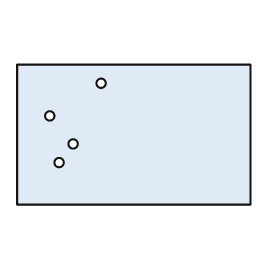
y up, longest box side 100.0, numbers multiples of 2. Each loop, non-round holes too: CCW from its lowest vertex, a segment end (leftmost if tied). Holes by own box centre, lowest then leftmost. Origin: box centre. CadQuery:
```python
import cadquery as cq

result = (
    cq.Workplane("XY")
    .moveTo(-50.0, -30.0)
    .lineTo(50.0, -30.0)
    .lineTo(50.0, 30.0)
    .lineTo(-50.0, 30.0)
    .close()
    .moveTo(-32.0, -12.0)
    .circle(2.0)
    .moveTo(-26.0, -4.0)
    .circle(2.0)
    .moveTo(-36.0, 8.0)
    .circle(2.0)
    .moveTo(-14.0, 22.0)
    .circle(2.0)
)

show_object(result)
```